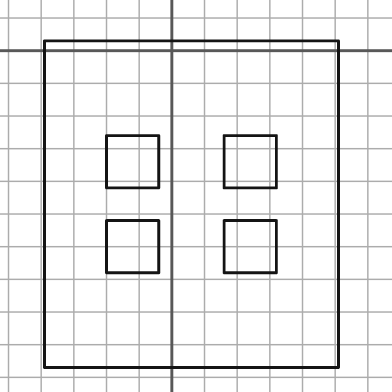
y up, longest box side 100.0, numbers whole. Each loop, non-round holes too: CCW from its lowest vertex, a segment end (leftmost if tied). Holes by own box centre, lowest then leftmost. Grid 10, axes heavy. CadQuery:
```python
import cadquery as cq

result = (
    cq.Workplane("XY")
    .moveTo(-39.0, -97.0)
    .lineTo(51.0, -97.0)
    .lineTo(51.0, 3.0)
    .lineTo(-39.0, 3.0)
    .close()
    .moveTo(-20.0, -68.0)
    .lineTo(-4.0, -68.0)
    .lineTo(-4.0, -52.0)
    .lineTo(-20.0, -52.0)
    .close()
    .moveTo(16.0, -68.0)
    .lineTo(32.0, -68.0)
    .lineTo(32.0, -52.0)
    .lineTo(16.0, -52.0)
    .close()
    .moveTo(-20.0, -42.0)
    .lineTo(-4.0, -42.0)
    .lineTo(-4.0, -26.0)
    .lineTo(-20.0, -26.0)
    .close()
    .moveTo(16.0, -42.0)
    .lineTo(32.0, -42.0)
    .lineTo(32.0, -26.0)
    .lineTo(16.0, -26.0)
    .close()
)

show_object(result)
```